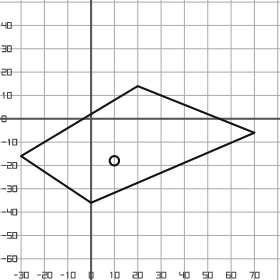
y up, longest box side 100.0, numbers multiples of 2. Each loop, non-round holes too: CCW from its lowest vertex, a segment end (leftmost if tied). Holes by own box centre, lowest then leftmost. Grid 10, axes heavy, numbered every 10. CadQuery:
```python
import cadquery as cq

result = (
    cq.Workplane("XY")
    .moveTo(0.0, -36.0)
    .lineTo(70.0, -6.0)
    .lineTo(20.0, 14.0)
    .lineTo(-30.0, -16.0)
    .close()
    .moveTo(10.0, -18.0)
    .circle(2.0)
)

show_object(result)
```